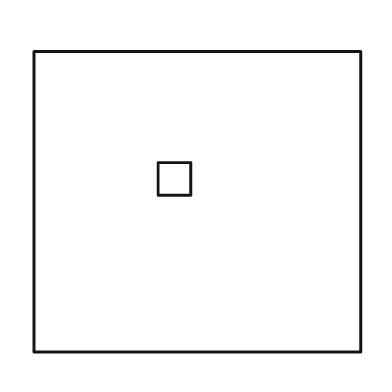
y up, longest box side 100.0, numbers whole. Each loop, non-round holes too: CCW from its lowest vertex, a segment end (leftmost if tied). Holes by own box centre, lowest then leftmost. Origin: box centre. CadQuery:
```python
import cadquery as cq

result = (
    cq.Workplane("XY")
    .moveTo(-50.0, -46.0)
    .lineTo(50.0, -46.0)
    .lineTo(50.0, 46.0)
    .lineTo(-50.0, 46.0)
    .close()
    .moveTo(-12.0, 2.0)
    .lineTo(-2.0, 2.0)
    .lineTo(-2.0, 12.0)
    .lineTo(-12.0, 12.0)
    .close()
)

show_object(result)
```